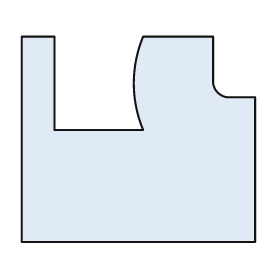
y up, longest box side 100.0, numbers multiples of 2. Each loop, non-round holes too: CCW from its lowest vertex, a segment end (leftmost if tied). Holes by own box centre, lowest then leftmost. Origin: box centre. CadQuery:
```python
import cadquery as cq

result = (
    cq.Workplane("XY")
    .moveTo(-50.0, -44.0)
    .lineTo(50.0, -44.0)
    .lineTo(50.0, 18.0)
    .lineTo(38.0, 18.0)
    .threePointArc((34.0, 20.0), (32.0, 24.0))
    .lineTo(32.0, 44.0)
    .lineTo(2.0, 44.0)
    .threePointArc((-2.0, 24.0), (2.0, 4.0))
    .lineTo(-36.0, 4.0)
    .lineTo(-36.0, 44.0)
    .lineTo(-50.0, 44.0)
    .close()
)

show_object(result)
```